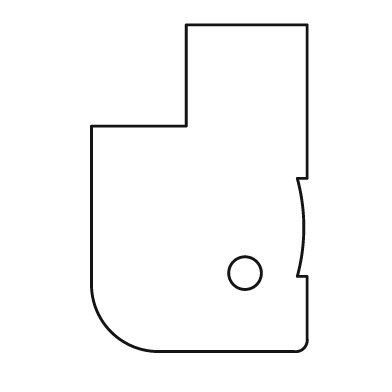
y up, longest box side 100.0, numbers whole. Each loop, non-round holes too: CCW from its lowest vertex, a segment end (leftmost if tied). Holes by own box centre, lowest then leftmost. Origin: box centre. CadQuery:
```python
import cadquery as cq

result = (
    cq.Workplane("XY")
    .moveTo(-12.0, -50.0)
    .lineTo(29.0, -50.0)
    .threePointArc((32.0, -49.0), (33.0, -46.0))
    .lineTo(33.0, -27.0)
    .lineTo(30.0, -27.0)
    .threePointArc((32.0, -12.0), (30.0, 3.0))
    .lineTo(33.0, 3.0)
    .lineTo(33.0, 50.0)
    .lineTo(-4.0, 50.0)
    .lineTo(-4.0, 19.0)
    .lineTo(-33.0, 19.0)
    .lineTo(-33.0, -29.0)
    .threePointArc((-27.0, -44.0), (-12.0, -50.0))
    .close()
    .moveTo(14.0, -26.0)
    .circle(5.0)
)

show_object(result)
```